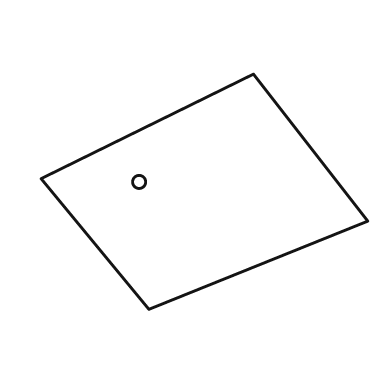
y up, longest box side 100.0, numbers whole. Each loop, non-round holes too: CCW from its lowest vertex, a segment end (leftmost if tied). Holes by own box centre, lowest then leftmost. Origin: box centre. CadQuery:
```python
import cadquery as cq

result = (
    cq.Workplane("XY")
    .moveTo(-17.0, -36.0)
    .lineTo(50.0, -9.0)
    .lineTo(15.0, 36.0)
    .lineTo(-50.0, 4.0)
    .close()
    .moveTo(-20.0, 3.0)
    .circle(2.0)
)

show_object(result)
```